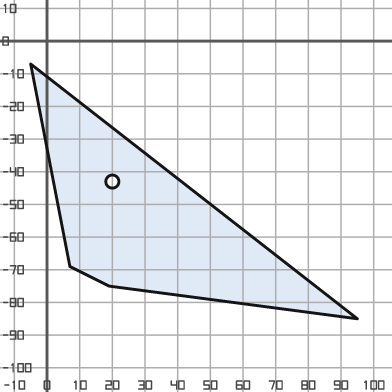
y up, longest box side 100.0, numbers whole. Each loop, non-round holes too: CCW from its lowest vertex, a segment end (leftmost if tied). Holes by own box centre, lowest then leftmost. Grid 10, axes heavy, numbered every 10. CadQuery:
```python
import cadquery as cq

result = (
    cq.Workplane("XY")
    .moveTo(95.0, -85.0)
    .lineTo(-5.0, -7.0)
    .lineTo(7.0, -69.0)
    .lineTo(19.0, -75.0)
    .close()
    .moveTo(20.0, -43.0)
    .circle(2.0)
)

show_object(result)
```